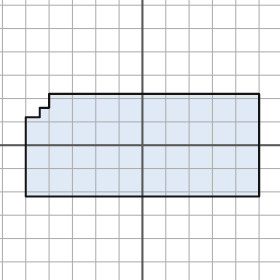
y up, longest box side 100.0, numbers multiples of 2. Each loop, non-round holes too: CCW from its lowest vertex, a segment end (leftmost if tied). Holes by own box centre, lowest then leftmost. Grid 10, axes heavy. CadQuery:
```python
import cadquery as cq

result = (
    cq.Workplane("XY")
    .moveTo(-50.0, -22.0)
    .lineTo(50.0, -22.0)
    .lineTo(50.0, 22.0)
    .lineTo(-40.0, 22.0)
    .lineTo(-40.0, 16.0)
    .lineTo(-44.0, 16.0)
    .lineTo(-44.0, 12.0)
    .lineTo(-50.0, 12.0)
    .close()
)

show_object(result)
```